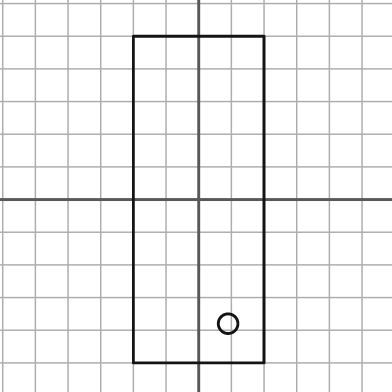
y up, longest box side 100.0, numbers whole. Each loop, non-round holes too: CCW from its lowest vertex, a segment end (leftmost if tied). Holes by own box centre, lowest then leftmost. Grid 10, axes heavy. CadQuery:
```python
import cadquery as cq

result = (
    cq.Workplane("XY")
    .moveTo(-20.0, -50.0)
    .lineTo(20.0, -50.0)
    .lineTo(20.0, 50.0)
    .lineTo(-20.0, 50.0)
    .close()
    .moveTo(9.0, -38.0)
    .circle(3.0)
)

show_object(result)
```